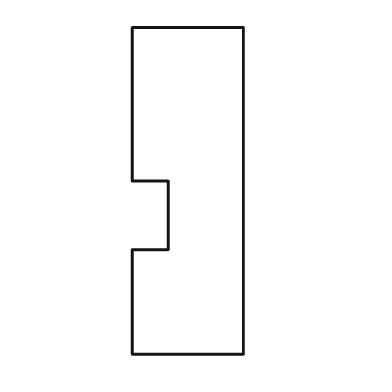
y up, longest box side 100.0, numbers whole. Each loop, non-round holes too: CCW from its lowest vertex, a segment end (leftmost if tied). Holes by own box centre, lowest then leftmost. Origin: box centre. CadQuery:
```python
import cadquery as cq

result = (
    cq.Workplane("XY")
    .moveTo(-17.0, -50.0)
    .lineTo(17.0, -50.0)
    .lineTo(17.0, 50.0)
    .lineTo(-17.0, 50.0)
    .lineTo(-17.0, 3.0)
    .lineTo(-6.0, 3.0)
    .lineTo(-6.0, -18.0)
    .lineTo(-17.0, -18.0)
    .close()
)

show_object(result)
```